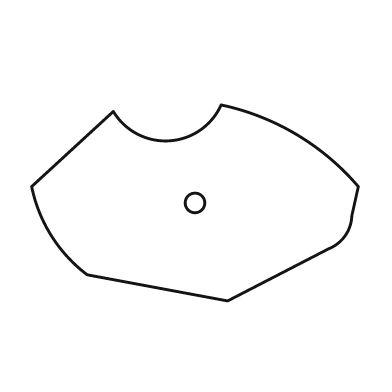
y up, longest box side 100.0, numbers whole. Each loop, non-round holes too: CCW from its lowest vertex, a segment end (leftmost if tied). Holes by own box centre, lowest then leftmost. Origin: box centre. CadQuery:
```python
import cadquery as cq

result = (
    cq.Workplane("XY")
    .moveTo(10.0, -30.0)
    .lineTo(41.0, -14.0)
    .threePointArc((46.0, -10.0), (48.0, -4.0))
    .lineTo(50.0, 5.0)
    .threePointArc((31.0, 21.0), (8.0, 30.0))
    .threePointArc((-8.0, 19.0), (-25.0, 28.0))
    .lineTo(-50.0, 5.0)
    .threePointArc((-44.0, -10.0), (-33.0, -22.0))
    .close()
    .moveTo(0.0, 0.0)
    .circle(3.0)
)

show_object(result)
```